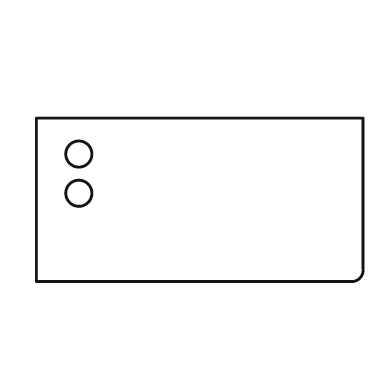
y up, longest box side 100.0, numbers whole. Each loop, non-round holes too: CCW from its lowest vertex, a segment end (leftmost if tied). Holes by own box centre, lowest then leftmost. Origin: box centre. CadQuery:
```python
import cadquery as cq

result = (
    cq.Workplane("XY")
    .moveTo(-50.0, -25.0)
    .lineTo(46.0, -25.0)
    .threePointArc((49.0, -24.0), (50.0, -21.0))
    .lineTo(50.0, 25.0)
    .lineTo(-50.0, 25.0)
    .close()
    .moveTo(-37.0, 2.0)
    .circle(4.0)
    .moveTo(-37.0, 14.0)
    .circle(4.0)
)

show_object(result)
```